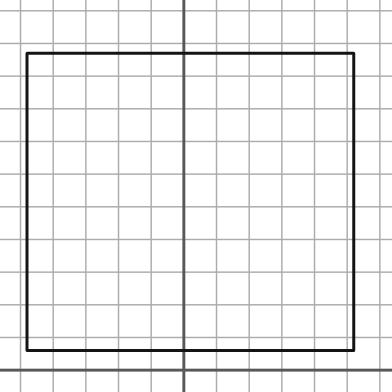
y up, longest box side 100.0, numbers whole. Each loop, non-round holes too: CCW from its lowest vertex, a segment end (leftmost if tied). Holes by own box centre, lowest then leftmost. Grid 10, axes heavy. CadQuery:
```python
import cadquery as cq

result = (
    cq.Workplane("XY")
    .moveTo(-48.0, 6.0)
    .lineTo(52.0, 6.0)
    .lineTo(52.0, 97.0)
    .lineTo(-48.0, 97.0)
    .close()
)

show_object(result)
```